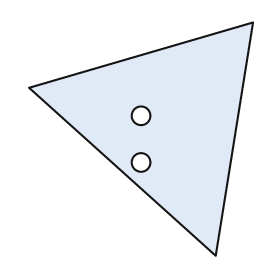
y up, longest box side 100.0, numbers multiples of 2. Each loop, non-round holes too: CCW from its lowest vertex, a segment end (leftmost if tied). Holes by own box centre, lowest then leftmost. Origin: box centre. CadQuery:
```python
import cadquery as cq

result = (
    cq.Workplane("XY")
    .moveTo(32.0, -50.0)
    .lineTo(48.0, 50.0)
    .lineTo(-48.0, 22.0)
    .close()
    .moveTo(0.0, -10.0)
    .circle(4.0)
    .moveTo(0.0, 10.0)
    .circle(4.0)
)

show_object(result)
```